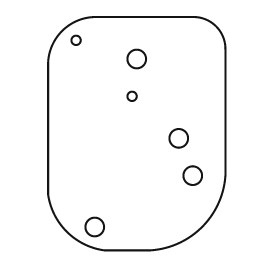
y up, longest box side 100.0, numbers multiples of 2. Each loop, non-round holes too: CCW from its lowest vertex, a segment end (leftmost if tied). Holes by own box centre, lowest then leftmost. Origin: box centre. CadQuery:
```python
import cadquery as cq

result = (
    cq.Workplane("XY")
    .moveTo(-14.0, -50.0)
    .lineTo(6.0, -50.0)
    .threePointArc((28.0, -40.0), (38.0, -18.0))
    .lineTo(38.0, 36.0)
    .threePointArc((34.0, 46.0), (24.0, 50.0))
    .lineTo(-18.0, 50.0)
    .threePointArc((-32.0, 44.0), (-38.0, 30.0))
    .lineTo(-38.0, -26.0)
    .threePointArc((-30.0, -42.0), (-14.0, -50.0))
    .close()
    .moveTo(-18.0, -40.0)
    .circle(4.0)
    .moveTo(24.0, -18.0)
    .circle(4.0)
    .moveTo(18.0, -2.0)
    .circle(4.0)
    .moveTo(-2.0, 16.0)
    .circle(2.0)
    .moveTo(0.0, 32.0)
    .circle(4.0)
    .moveTo(-26.0, 40.0)
    .circle(2.0)
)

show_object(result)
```